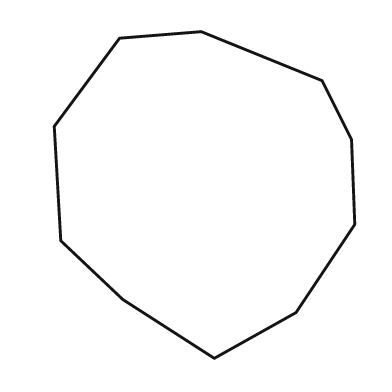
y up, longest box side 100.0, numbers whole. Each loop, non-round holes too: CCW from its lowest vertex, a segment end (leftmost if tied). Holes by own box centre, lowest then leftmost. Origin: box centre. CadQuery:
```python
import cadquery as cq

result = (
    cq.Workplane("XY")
    .moveTo(3.0, -50.0)
    .lineTo(28.0, -36.0)
    .lineTo(46.0, -9.0)
    .lineTo(45.0, 17.0)
    .lineTo(36.0, 35.0)
    .lineTo(-1.0, 50.0)
    .lineTo(-26.0, 48.0)
    .lineTo(-46.0, 21.0)
    .lineTo(-44.0, -14.0)
    .lineTo(-25.0, -32.0)
    .close()
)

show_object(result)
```